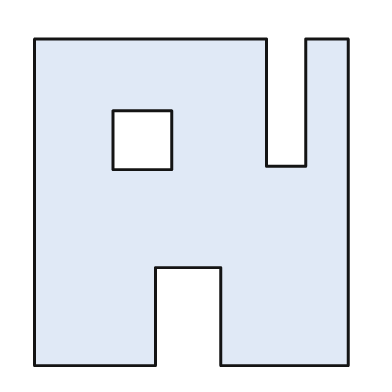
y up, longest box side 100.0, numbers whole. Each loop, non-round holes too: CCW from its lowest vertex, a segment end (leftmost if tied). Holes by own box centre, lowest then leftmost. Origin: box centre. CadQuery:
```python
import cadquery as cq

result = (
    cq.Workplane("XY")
    .moveTo(-48.0, -50.0)
    .lineTo(-11.0, -50.0)
    .lineTo(-11.0, -20.0)
    .lineTo(9.0, -20.0)
    .lineTo(9.0, -50.0)
    .lineTo(48.0, -50.0)
    .lineTo(48.0, 50.0)
    .lineTo(35.0, 50.0)
    .lineTo(35.0, 11.0)
    .lineTo(23.0, 11.0)
    .lineTo(23.0, 50.0)
    .lineTo(-48.0, 50.0)
    .close()
    .moveTo(-24.0, 10.0)
    .lineTo(-6.0, 10.0)
    .lineTo(-6.0, 28.0)
    .lineTo(-24.0, 28.0)
    .close()
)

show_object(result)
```